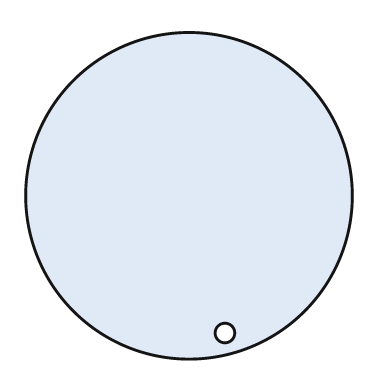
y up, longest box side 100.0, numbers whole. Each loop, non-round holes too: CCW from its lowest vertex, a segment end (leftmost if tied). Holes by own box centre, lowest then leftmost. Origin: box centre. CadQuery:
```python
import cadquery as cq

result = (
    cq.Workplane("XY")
    .moveTo(0.0, 0.0)
    .circle(50.0)
    .moveTo(11.0, -42.0)
    .circle(3.0)
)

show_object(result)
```